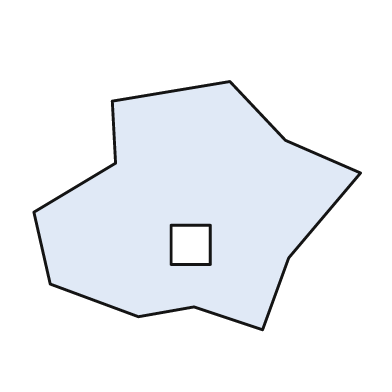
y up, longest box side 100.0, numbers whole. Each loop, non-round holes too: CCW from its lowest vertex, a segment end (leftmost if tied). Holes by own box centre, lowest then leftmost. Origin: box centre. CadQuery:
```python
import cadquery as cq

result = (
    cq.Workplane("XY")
    .moveTo(20.0, -38.0)
    .lineTo(28.0, -16.0)
    .lineTo(50.0, 10.0)
    .lineTo(27.0, 20.0)
    .lineTo(10.0, 38.0)
    .lineTo(-26.0, 32.0)
    .lineTo(-25.0, 13.0)
    .lineTo(-50.0, -2.0)
    .lineTo(-45.0, -24.0)
    .lineTo(-18.0, -34.0)
    .lineTo(-1.0, -31.0)
    .close()
    .moveTo(-8.0, -18.0)
    .lineTo(4.0, -18.0)
    .lineTo(4.0, -6.0)
    .lineTo(-8.0, -6.0)
    .close()
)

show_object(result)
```